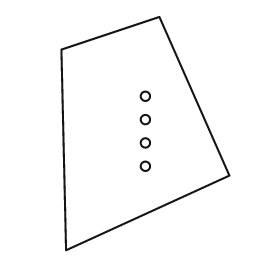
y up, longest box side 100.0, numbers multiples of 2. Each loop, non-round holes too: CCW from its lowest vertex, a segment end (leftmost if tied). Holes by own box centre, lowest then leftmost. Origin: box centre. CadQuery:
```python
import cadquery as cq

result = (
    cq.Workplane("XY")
    .moveTo(-34.0, -50.0)
    .lineTo(36.0, -18.0)
    .lineTo(6.0, 50.0)
    .lineTo(-36.0, 36.0)
    .close()
    .moveTo(0.0, -14.0)
    .circle(2.0)
    .moveTo(0.0, -4.0)
    .circle(2.0)
    .moveTo(0.0, 6.0)
    .circle(2.0)
    .moveTo(0.0, 16.0)
    .circle(2.0)
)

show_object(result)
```